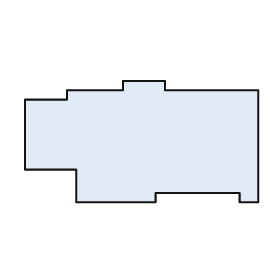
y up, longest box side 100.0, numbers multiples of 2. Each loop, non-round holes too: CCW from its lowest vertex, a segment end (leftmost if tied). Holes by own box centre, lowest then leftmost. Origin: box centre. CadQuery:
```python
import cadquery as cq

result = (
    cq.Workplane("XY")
    .moveTo(-28.0, -26.0)
    .lineTo(6.0, -26.0)
    .lineTo(6.0, -22.0)
    .lineTo(42.0, -22.0)
    .lineTo(42.0, -26.0)
    .lineTo(50.0, -26.0)
    .lineTo(50.0, 22.0)
    .lineTo(10.0, 22.0)
    .lineTo(10.0, 26.0)
    .lineTo(-8.0, 26.0)
    .lineTo(-8.0, 22.0)
    .lineTo(-32.0, 22.0)
    .lineTo(-32.0, 18.0)
    .lineTo(-50.0, 18.0)
    .lineTo(-50.0, -12.0)
    .lineTo(-28.0, -12.0)
    .close()
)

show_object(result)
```